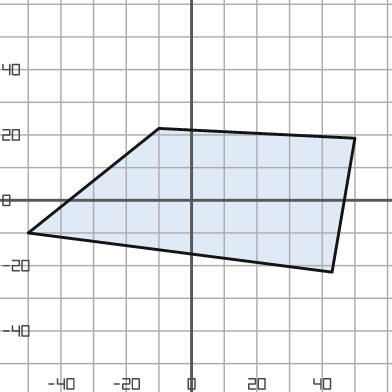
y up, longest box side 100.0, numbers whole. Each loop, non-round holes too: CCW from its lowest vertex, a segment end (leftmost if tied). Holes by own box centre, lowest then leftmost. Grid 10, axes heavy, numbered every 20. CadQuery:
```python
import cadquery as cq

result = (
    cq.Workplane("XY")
    .moveTo(43.0, -22.0)
    .lineTo(50.0, 19.0)
    .lineTo(-10.0, 22.0)
    .lineTo(-50.0, -10.0)
    .close()
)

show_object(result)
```